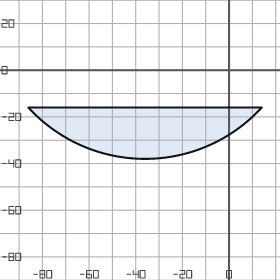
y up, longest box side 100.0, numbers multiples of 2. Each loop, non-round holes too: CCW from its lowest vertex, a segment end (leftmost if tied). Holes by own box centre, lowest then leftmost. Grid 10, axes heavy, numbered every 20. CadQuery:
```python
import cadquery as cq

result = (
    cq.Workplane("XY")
    .moveTo(-86.0, -16.0)
    .threePointArc((-36.0, -38.0), (14.0, -16.0))
    .close()
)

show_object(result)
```